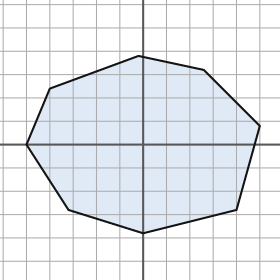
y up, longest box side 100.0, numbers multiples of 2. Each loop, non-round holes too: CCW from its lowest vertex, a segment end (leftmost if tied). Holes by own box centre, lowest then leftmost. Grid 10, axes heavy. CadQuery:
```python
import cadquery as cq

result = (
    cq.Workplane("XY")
    .moveTo(0.0, -38.0)
    .lineTo(40.0, -28.0)
    .lineTo(50.0, 8.0)
    .lineTo(26.0, 32.0)
    .lineTo(-2.0, 38.0)
    .lineTo(-40.0, 24.0)
    .lineTo(-50.0, 0.0)
    .lineTo(-32.0, -28.0)
    .close()
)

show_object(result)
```